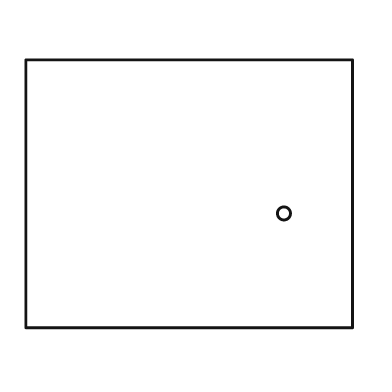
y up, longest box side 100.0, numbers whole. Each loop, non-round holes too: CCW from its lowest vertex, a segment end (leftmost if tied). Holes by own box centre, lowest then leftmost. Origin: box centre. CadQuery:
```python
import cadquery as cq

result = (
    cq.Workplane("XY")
    .moveTo(-50.0, -41.0)
    .lineTo(50.0, -41.0)
    .lineTo(50.0, 41.0)
    .lineTo(-50.0, 41.0)
    .close()
    .moveTo(29.0, -6.0)
    .circle(2.0)
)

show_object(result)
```